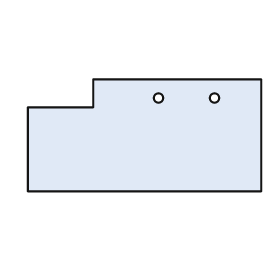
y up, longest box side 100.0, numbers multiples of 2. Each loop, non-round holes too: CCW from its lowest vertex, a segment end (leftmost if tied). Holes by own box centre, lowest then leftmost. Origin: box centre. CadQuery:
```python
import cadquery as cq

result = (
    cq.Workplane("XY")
    .moveTo(-50.0, -24.0)
    .lineTo(50.0, -24.0)
    .lineTo(50.0, 24.0)
    .lineTo(-22.0, 24.0)
    .lineTo(-22.0, 12.0)
    .lineTo(-50.0, 12.0)
    .close()
    .moveTo(6.0, 16.0)
    .circle(2.0)
    .moveTo(30.0, 16.0)
    .circle(2.0)
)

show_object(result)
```